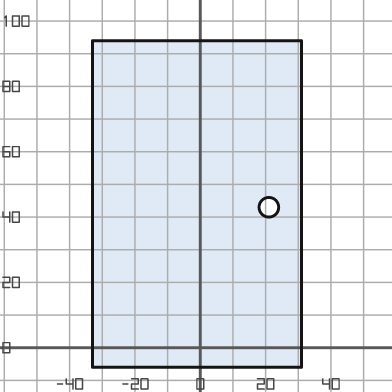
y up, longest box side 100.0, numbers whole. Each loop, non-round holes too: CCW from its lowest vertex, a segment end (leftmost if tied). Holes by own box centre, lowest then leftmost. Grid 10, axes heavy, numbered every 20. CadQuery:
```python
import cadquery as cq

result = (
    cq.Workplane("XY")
    .moveTo(-33.0, -6.0)
    .lineTo(31.0, -6.0)
    .lineTo(31.0, 94.0)
    .lineTo(-33.0, 94.0)
    .close()
    .moveTo(21.0, 43.0)
    .circle(3.0)
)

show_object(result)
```